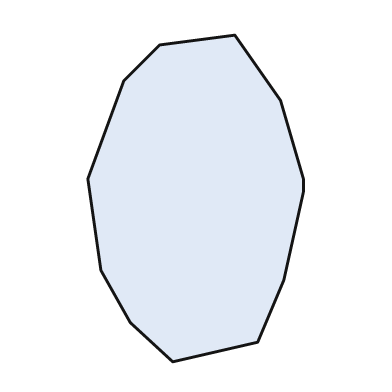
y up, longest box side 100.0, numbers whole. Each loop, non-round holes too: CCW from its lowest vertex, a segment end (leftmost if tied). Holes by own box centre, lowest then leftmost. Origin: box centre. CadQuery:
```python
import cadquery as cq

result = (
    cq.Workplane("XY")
    .moveTo(-7.0, -50.0)
    .lineTo(19.0, -44.0)
    .lineTo(27.0, -25.0)
    .lineTo(33.0, 2.0)
    .lineTo(33.0, 6.0)
    .lineTo(26.0, 30.0)
    .lineTo(12.0, 50.0)
    .lineTo(-11.0, 47.0)
    .lineTo(-22.0, 36.0)
    .lineTo(-33.0, 6.0)
    .lineTo(-29.0, -22.0)
    .lineTo(-20.0, -38.0)
    .close()
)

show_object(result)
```